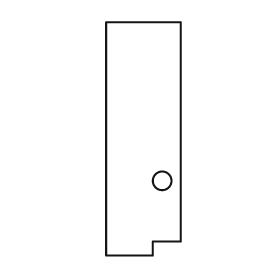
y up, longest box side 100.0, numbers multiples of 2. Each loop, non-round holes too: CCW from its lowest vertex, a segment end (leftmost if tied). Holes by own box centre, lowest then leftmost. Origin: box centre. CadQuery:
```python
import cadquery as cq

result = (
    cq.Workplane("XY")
    .moveTo(-16.0, -50.0)
    .lineTo(4.0, -50.0)
    .lineTo(4.0, -44.0)
    .lineTo(16.0, -44.0)
    .lineTo(16.0, 50.0)
    .lineTo(-16.0, 50.0)
    .close()
    .moveTo(8.0, -18.0)
    .circle(4.0)
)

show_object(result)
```